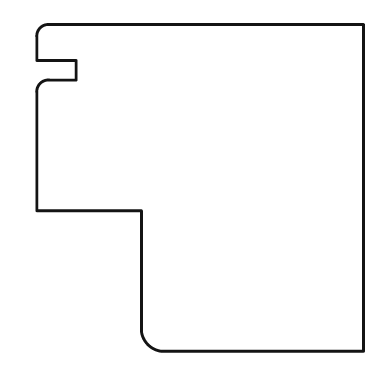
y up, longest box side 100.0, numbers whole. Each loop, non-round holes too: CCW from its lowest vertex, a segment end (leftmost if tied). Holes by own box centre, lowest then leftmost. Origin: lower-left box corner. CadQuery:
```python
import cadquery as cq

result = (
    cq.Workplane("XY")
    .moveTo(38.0, 0.0)
    .lineTo(100.0, 0.0)
    .lineTo(100.0, 100.0)
    .lineTo(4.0, 100.0)
    .threePointArc((1.0, 99.0), (0.0, 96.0))
    .lineTo(0.0, 89.0)
    .lineTo(12.0, 89.0)
    .lineTo(12.0, 83.0)
    .lineTo(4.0, 83.0)
    .threePointArc((1.0, 82.0), (0.0, 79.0))
    .lineTo(0.0, 43.0)
    .lineTo(32.0, 43.0)
    .lineTo(32.0, 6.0)
    .threePointArc((34.0, 2.0), (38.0, 0.0))
    .close()
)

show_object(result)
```